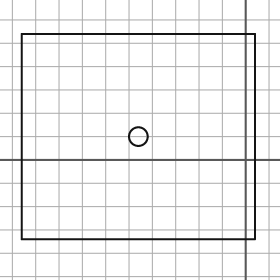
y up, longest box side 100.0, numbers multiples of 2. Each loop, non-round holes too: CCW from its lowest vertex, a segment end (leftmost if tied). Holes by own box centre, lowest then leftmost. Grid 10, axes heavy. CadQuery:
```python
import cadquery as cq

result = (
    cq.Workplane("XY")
    .moveTo(-96.0, -34.0)
    .lineTo(4.0, -34.0)
    .lineTo(4.0, 54.0)
    .lineTo(-96.0, 54.0)
    .close()
    .moveTo(-46.0, 10.0)
    .circle(4.0)
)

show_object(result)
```